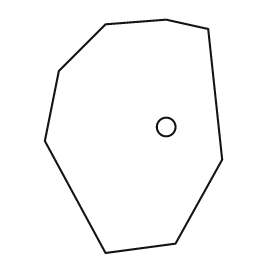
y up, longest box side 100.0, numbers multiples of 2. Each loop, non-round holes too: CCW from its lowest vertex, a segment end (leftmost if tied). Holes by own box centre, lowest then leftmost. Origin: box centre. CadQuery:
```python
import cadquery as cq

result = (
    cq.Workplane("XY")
    .moveTo(-12.0, -50.0)
    .lineTo(18.0, -46.0)
    .lineTo(38.0, -10.0)
    .lineTo(32.0, 46.0)
    .lineTo(14.0, 50.0)
    .lineTo(-12.0, 48.0)
    .lineTo(-32.0, 28.0)
    .lineTo(-38.0, -2.0)
    .close()
    .moveTo(14.0, 4.0)
    .circle(4.0)
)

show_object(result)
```